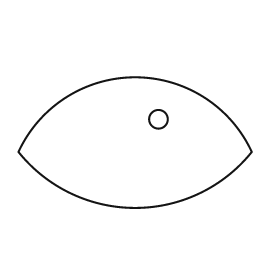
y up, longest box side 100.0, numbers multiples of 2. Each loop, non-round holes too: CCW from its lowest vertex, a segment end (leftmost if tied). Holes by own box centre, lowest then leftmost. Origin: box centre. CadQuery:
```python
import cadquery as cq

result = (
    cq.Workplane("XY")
    .moveTo(-50.0, -4.0)
    .threePointArc((0.0, -28.0), (50.0, -4.0))
    .threePointArc((0.0, 28.0), (-50.0, -4.0))
    .close()
    .moveTo(10.0, 10.0)
    .circle(4.0)
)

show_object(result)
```